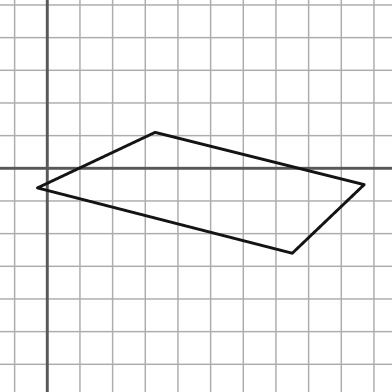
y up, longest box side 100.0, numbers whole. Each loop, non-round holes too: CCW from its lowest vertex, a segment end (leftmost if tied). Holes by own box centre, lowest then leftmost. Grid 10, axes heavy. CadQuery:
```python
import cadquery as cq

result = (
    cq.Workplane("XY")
    .moveTo(75.0, -26.0)
    .lineTo(97.0, -5.0)
    .lineTo(33.0, 11.0)
    .lineTo(-3.0, -6.0)
    .close()
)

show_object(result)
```